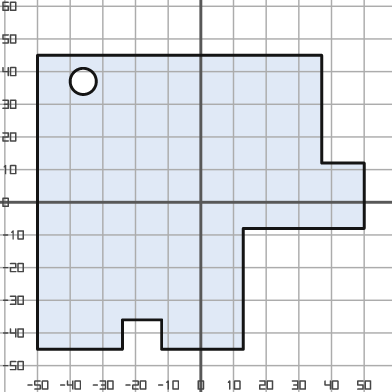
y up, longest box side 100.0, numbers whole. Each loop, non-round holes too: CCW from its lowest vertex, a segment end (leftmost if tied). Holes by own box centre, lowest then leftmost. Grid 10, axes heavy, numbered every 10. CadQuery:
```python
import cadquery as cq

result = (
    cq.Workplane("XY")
    .moveTo(-50.0, -45.0)
    .lineTo(-24.0, -45.0)
    .lineTo(-24.0, -36.0)
    .lineTo(-12.0, -36.0)
    .lineTo(-12.0, -45.0)
    .lineTo(13.0, -45.0)
    .lineTo(13.0, -8.0)
    .lineTo(50.0, -8.0)
    .lineTo(50.0, 12.0)
    .lineTo(37.0, 12.0)
    .lineTo(37.0, 45.0)
    .lineTo(-50.0, 45.0)
    .close()
    .moveTo(-36.0, 37.0)
    .circle(4.0)
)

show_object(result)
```